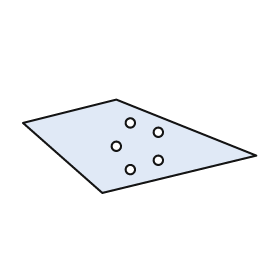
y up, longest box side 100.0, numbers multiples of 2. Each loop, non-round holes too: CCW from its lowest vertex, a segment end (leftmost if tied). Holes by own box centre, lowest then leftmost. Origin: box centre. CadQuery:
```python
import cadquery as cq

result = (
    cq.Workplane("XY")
    .moveTo(-16.0, -20.0)
    .lineTo(50.0, -4.0)
    .lineTo(-10.0, 20.0)
    .lineTo(-50.0, 10.0)
    .close()
    .moveTo(-4.0, -10.0)
    .circle(2.0)
    .moveTo(8.0, -6.0)
    .circle(2.0)
    .moveTo(-10.0, 0.0)
    .circle(2.0)
    .moveTo(8.0, 6.0)
    .circle(2.0)
    .moveTo(-4.0, 10.0)
    .circle(2.0)
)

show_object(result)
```